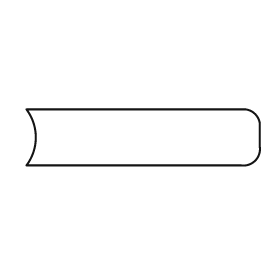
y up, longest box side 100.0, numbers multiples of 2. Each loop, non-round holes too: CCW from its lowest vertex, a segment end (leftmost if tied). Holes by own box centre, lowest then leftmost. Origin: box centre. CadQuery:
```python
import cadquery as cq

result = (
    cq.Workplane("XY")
    .moveTo(-50.0, -12.0)
    .lineTo(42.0, -12.0)
    .threePointArc((48.0, -10.0), (50.0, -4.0))
    .lineTo(50.0, 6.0)
    .threePointArc((48.0, 10.0), (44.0, 12.0))
    .lineTo(-50.0, 12.0)
    .threePointArc((-46.0, 0.0), (-50.0, -12.0))
    .close()
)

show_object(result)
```